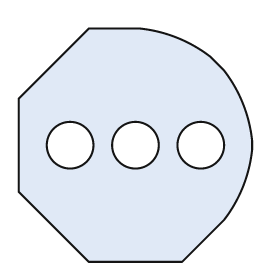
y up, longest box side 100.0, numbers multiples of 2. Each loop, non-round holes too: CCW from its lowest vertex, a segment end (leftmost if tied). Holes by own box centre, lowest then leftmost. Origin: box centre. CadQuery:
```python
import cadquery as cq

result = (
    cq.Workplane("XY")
    .moveTo(-20.0, -50.0)
    .lineTo(20.0, -50.0)
    .lineTo(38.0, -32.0)
    .threePointArc((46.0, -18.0), (50.0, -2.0))
    .lineTo(50.0, 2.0)
    .threePointArc((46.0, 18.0), (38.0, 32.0))
    .lineTo(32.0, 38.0)
    .threePointArc((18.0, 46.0), (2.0, 50.0))
    .lineTo(-20.0, 50.0)
    .lineTo(-50.0, 20.0)
    .lineTo(-50.0, -20.0)
    .close()
    .moveTo(-28.0, 0.0)
    .circle(10.0)
    .moveTo(0.0, 0.0)
    .circle(10.0)
    .moveTo(28.0, 0.0)
    .circle(10.0)
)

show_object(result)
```